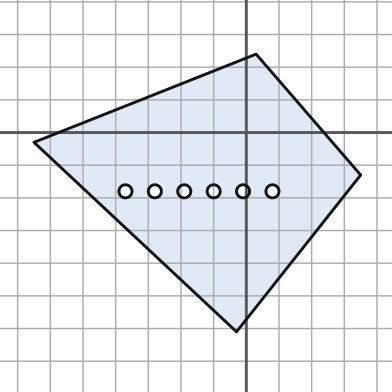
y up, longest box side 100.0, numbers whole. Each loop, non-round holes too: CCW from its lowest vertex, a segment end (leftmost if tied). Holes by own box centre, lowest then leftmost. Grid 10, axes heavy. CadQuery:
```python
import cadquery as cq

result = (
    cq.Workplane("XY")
    .moveTo(-3.0, -61.0)
    .lineTo(35.0, -13.0)
    .lineTo(3.0, 24.0)
    .lineTo(-65.0, -3.0)
    .close()
    .moveTo(-37.0, -18.0)
    .circle(2.0)
    .moveTo(-28.0, -18.0)
    .circle(2.0)
    .moveTo(-19.0, -18.0)
    .circle(2.0)
    .moveTo(-10.0, -18.0)
    .circle(2.0)
    .moveTo(-1.0, -18.0)
    .circle(2.0)
    .moveTo(8.0, -18.0)
    .circle(2.0)
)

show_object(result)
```